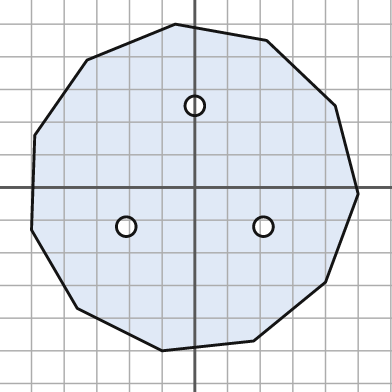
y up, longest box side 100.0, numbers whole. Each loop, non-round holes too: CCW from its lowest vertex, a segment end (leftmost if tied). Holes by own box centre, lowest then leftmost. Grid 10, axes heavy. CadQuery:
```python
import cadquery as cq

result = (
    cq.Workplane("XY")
    .moveTo(-10.0, -50.0)
    .lineTo(18.0, -47.0)
    .lineTo(40.0, -29.0)
    .lineTo(50.0, -2.0)
    .lineTo(43.0, 25.0)
    .lineTo(22.0, 45.0)
    .lineTo(-6.0, 50.0)
    .lineTo(-33.0, 39.0)
    .lineTo(-49.0, 16.0)
    .lineTo(-50.0, -13.0)
    .lineTo(-36.0, -37.0)
    .close()
    .moveTo(-21.0, -12.0)
    .circle(3.0)
    .moveTo(21.0, -12.0)
    .circle(3.0)
    .moveTo(0.0, 25.0)
    .circle(3.0)
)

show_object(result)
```